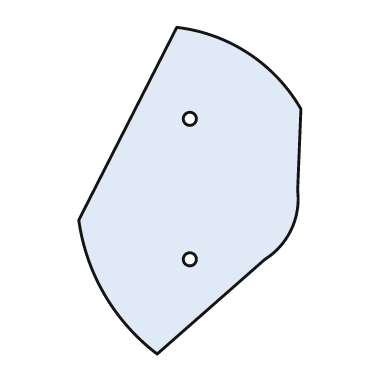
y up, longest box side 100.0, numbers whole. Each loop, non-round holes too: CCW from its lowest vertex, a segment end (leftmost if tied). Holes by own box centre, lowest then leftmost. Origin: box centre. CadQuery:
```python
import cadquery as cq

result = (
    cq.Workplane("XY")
    .moveTo(-10.0, -50.0)
    .lineTo(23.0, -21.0)
    .threePointArc((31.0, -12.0), (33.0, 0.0))
    .lineTo(34.0, 25.0)
    .threePointArc((18.0, 42.0), (-4.0, 50.0))
    .lineTo(-34.0, -9.0)
    .threePointArc((-26.0, -32.0), (-10.0, -50.0))
    .close()
    .moveTo(0.0, -21.0)
    .circle(2.0)
    .moveTo(0.0, 22.0)
    .circle(2.0)
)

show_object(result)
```